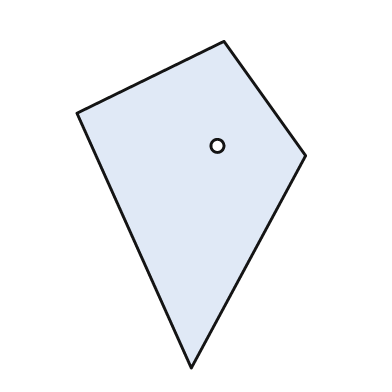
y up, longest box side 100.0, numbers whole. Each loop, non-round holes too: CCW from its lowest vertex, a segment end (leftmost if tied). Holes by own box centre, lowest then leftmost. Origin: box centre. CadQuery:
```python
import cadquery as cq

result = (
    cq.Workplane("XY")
    .moveTo(0.0, -50.0)
    .lineTo(35.0, 15.0)
    .lineTo(10.0, 50.0)
    .lineTo(-35.0, 28.0)
    .close()
    .moveTo(8.0, 18.0)
    .circle(2.0)
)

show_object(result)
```